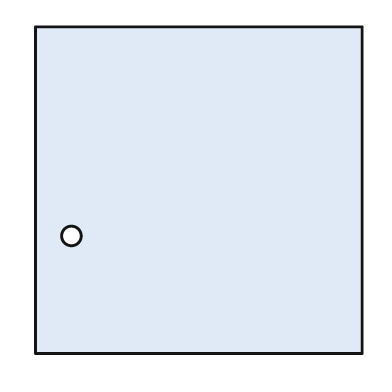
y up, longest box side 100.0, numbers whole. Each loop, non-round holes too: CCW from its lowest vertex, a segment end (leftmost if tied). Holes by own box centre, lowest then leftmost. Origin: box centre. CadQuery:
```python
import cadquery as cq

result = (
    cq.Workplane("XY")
    .moveTo(-50.0, -50.0)
    .lineTo(50.0, -50.0)
    .lineTo(50.0, 50.0)
    .lineTo(-50.0, 50.0)
    .close()
    .moveTo(-39.0, -14.0)
    .circle(3.0)
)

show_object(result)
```